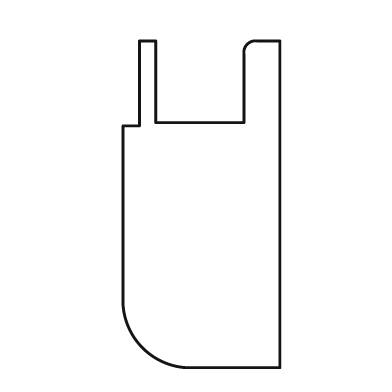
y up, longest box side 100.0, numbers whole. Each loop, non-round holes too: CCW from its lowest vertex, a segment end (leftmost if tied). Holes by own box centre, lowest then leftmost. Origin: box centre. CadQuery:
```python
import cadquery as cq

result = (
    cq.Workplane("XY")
    .moveTo(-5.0, -50.0)
    .lineTo(24.0, -50.0)
    .lineTo(24.0, 50.0)
    .lineTo(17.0, 50.0)
    .threePointArc((14.0, 49.0), (13.0, 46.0))
    .lineTo(13.0, 25.0)
    .lineTo(-14.0, 25.0)
    .lineTo(-14.0, 50.0)
    .lineTo(-19.0, 50.0)
    .lineTo(-19.0, 24.0)
    .lineTo(-24.0, 24.0)
    .lineTo(-24.0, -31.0)
    .threePointArc((-18.0, -44.0), (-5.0, -50.0))
    .close()
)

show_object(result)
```